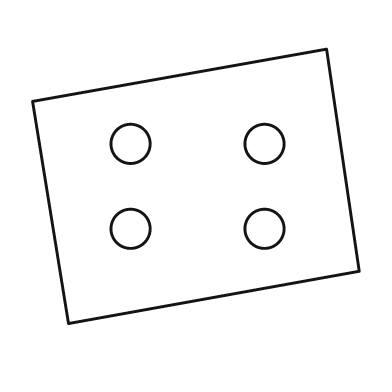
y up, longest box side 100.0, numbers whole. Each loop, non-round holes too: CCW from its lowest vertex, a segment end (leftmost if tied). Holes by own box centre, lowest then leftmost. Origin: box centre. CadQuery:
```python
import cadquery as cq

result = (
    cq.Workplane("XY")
    .moveTo(-39.0, -42.0)
    .lineTo(50.0, -26.0)
    .lineTo(40.0, 42.0)
    .lineTo(-50.0, 26.0)
    .close()
    .moveTo(-20.0, -13.0)
    .circle(6.0)
    .moveTo(21.0, -13.0)
    .circle(6.0)
    .moveTo(-20.0, 13.0)
    .circle(6.0)
    .moveTo(21.0, 13.0)
    .circle(6.0)
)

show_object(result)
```